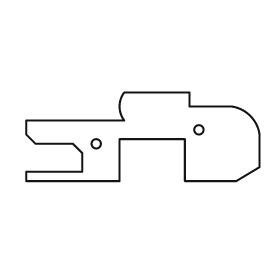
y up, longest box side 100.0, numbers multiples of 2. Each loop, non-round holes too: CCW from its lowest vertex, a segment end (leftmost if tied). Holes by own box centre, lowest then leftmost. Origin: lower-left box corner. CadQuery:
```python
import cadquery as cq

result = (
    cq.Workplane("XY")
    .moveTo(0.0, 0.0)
    .lineTo(40.0, 0.0)
    .lineTo(40.0, 18.0)
    .lineTo(68.0, 18.0)
    .lineTo(68.0, 0.0)
    .lineTo(90.0, 0.0)
    .lineTo(100.0, 6.0)
    .lineTo(100.0, 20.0)
    .threePointArc((96.0, 28.0), (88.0, 32.0))
    .lineTo(70.0, 32.0)
    .lineTo(70.0, 38.0)
    .lineTo(42.0, 38.0)
    .threePointArc((40.0, 32.0), (42.0, 26.0))
    .lineTo(0.0, 26.0)
    .lineTo(0.0, 20.0)
    .lineTo(4.0, 16.0)
    .lineTo(20.0, 16.0)
    .lineTo(24.0, 12.0)
    .lineTo(24.0, 4.0)
    .lineTo(0.0, 4.0)
    .close()
    .moveTo(30.0, 16.0)
    .circle(2.0)
    .moveTo(74.0, 22.0)
    .circle(2.0)
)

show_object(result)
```